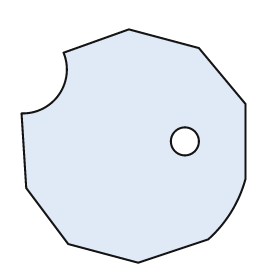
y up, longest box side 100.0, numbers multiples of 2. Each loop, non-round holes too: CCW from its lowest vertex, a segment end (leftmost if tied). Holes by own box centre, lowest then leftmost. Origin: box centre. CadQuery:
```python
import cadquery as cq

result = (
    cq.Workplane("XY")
    .moveTo(2.0, -50.0)
    .lineTo(32.0, -40.0)
    .threePointArc((42.0, -28.0), (48.0, -14.0))
    .lineTo(48.0, 18.0)
    .lineTo(28.0, 42.0)
    .lineTo(-2.0, 50.0)
    .lineTo(-30.0, 40.0)
    .threePointArc((-32.0, 22.0), (-48.0, 14.0))
    .lineTo(-46.0, -18.0)
    .lineTo(-28.0, -42.0)
    .close()
    .moveTo(22.0, 2.0)
    .circle(6.0)
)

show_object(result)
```